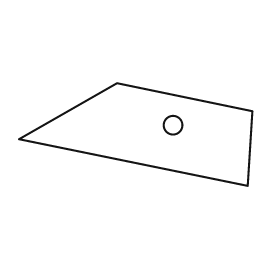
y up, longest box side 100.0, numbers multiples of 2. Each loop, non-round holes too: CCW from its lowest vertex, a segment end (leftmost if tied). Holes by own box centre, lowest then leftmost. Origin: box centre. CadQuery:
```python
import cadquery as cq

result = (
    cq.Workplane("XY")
    .moveTo(48.0, -22.0)
    .lineTo(50.0, 10.0)
    .lineTo(-8.0, 22.0)
    .lineTo(-50.0, -2.0)
    .close()
    .moveTo(16.0, 4.0)
    .circle(4.0)
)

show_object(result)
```